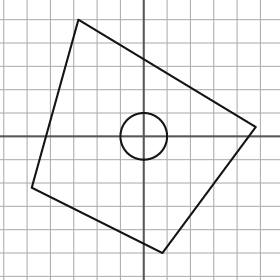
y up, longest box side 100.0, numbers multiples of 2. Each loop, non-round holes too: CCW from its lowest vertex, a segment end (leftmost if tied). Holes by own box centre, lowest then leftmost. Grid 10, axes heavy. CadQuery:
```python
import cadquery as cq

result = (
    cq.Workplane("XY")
    .moveTo(8.0, -50.0)
    .lineTo(48.0, 4.0)
    .lineTo(-28.0, 50.0)
    .lineTo(-48.0, -22.0)
    .close()
    .moveTo(0.0, 0.0)
    .circle(10.0)
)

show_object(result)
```